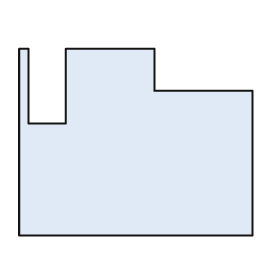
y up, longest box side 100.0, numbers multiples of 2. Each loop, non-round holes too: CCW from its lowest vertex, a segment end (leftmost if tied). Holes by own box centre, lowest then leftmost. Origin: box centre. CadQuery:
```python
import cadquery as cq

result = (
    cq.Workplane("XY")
    .moveTo(-50.0, -40.0)
    .lineTo(50.0, -40.0)
    .lineTo(50.0, 22.0)
    .lineTo(8.0, 22.0)
    .lineTo(8.0, 40.0)
    .lineTo(-30.0, 40.0)
    .lineTo(-30.0, 8.0)
    .lineTo(-46.0, 8.0)
    .lineTo(-46.0, 40.0)
    .lineTo(-50.0, 40.0)
    .close()
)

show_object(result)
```